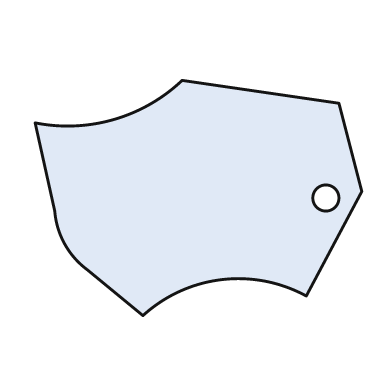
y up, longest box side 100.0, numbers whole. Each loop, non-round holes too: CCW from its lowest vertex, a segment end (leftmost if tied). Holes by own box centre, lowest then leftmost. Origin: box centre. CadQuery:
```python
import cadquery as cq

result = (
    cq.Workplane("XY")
    .moveTo(-17.0, -36.0)
    .threePointArc((7.0, -25.0), (33.0, -30.0))
    .lineTo(50.0, 2.0)
    .lineTo(43.0, 29.0)
    .lineTo(-5.0, 36.0)
    .threePointArc((-26.0, 24.0), (-50.0, 23.0))
    .lineTo(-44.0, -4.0)
    .threePointArc((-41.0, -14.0), (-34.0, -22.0))
    .close()
    .moveTo(39.0, 0.0)
    .circle(4.0)
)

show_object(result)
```